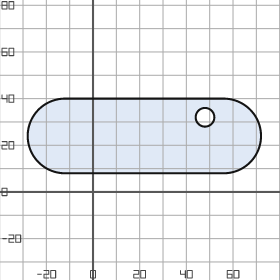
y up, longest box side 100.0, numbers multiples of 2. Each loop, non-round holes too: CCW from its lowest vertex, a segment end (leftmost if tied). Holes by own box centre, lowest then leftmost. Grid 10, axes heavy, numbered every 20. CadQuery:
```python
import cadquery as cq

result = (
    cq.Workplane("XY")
    .moveTo(-12.0, 8.0)
    .lineTo(56.0, 8.0)
    .threePointArc((72.0, 24.0), (56.0, 40.0))
    .lineTo(-12.0, 40.0)
    .threePointArc((-28.0, 24.0), (-12.0, 8.0))
    .close()
    .moveTo(48.0, 32.0)
    .circle(4.0)
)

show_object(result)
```